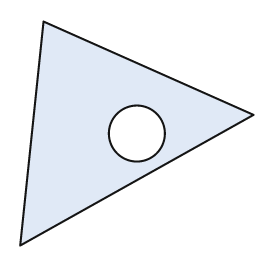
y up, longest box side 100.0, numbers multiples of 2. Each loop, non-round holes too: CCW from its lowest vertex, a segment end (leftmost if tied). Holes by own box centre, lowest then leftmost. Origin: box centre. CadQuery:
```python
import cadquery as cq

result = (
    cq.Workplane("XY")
    .moveTo(-50.0, -48.0)
    .lineTo(50.0, 8.0)
    .lineTo(-40.0, 48.0)
    .close()
    .moveTo(0.0, 0.0)
    .circle(12.0)
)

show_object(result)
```